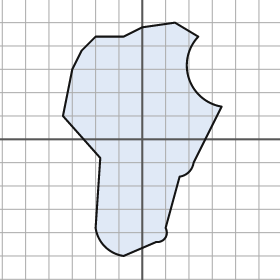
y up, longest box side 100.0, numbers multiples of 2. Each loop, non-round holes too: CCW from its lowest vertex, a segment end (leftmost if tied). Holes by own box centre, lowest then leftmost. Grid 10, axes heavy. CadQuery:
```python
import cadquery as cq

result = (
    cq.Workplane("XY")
    .moveTo(-8.0, -50.0)
    .lineTo(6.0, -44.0)
    .threePointArc((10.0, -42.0), (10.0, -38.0))
    .lineTo(16.0, -16.0)
    .threePointArc((20.0, -14.0), (22.0, -10.0))
    .lineTo(34.0, 14.0)
    .threePointArc((20.0, 26.0), (24.0, 44.0))
    .lineTo(14.0, 50.0)
    .lineTo(0.0, 48.0)
    .lineTo(-8.0, 44.0)
    .lineTo(-20.0, 44.0)
    .lineTo(-26.0, 38.0)
    .lineTo(-30.0, 30.0)
    .lineTo(-34.0, 10.0)
    .lineTo(-18.0, -8.0)
    .lineTo(-20.0, -38.0)
    .threePointArc((-16.0, -46.0), (-8.0, -50.0))
    .close()
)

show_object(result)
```